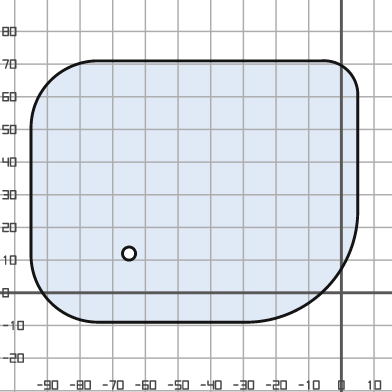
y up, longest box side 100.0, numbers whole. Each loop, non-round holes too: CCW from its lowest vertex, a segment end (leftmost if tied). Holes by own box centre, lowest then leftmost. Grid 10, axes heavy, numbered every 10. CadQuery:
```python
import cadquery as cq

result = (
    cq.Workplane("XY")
    .moveTo(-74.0, -9.0)
    .lineTo(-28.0, -9.0)
    .threePointArc((-5.0, 1.0), (5.0, 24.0))
    .lineTo(5.0, 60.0)
    .threePointArc((2.0, 68.0), (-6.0, 71.0))
    .lineTo(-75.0, 71.0)
    .threePointArc((-89.0, 65.0), (-95.0, 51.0))
    .lineTo(-95.0, 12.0)
    .threePointArc((-89.0, -3.0), (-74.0, -9.0))
    .close()
    .moveTo(-65.0, 12.0)
    .circle(2.0)
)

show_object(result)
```